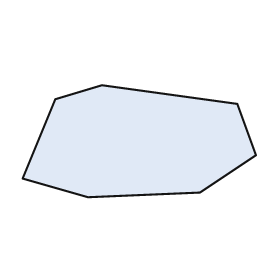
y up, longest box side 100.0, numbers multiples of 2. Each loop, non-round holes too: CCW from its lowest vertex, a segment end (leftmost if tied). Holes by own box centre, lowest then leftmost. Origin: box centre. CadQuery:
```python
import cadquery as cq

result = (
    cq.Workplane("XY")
    .moveTo(-22.0, -24.0)
    .lineTo(26.0, -22.0)
    .lineTo(50.0, -6.0)
    .lineTo(42.0, 16.0)
    .lineTo(-16.0, 24.0)
    .lineTo(-36.0, 18.0)
    .lineTo(-50.0, -16.0)
    .close()
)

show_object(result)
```